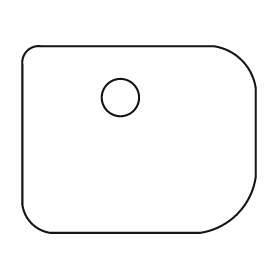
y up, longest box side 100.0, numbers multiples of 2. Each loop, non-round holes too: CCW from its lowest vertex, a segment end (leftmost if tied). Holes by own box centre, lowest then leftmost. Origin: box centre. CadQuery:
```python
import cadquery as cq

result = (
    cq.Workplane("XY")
    .moveTo(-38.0, -40.0)
    .lineTo(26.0, -40.0)
    .threePointArc((42.0, -32.0), (50.0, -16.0))
    .lineTo(50.0, 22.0)
    .threePointArc((44.0, 34.0), (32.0, 40.0))
    .lineTo(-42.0, 40.0)
    .threePointArc((-48.0, 38.0), (-50.0, 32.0))
    .lineTo(-50.0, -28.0)
    .threePointArc((-46.0, -36.0), (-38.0, -40.0))
    .close()
    .moveTo(-8.0, 18.0)
    .circle(8.0)
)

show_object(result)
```